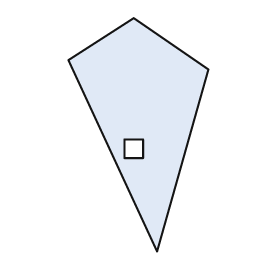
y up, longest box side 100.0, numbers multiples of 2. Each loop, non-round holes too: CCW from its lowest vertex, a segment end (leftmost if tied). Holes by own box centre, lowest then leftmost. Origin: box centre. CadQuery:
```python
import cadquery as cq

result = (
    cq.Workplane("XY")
    .moveTo(8.0, -50.0)
    .lineTo(30.0, 28.0)
    .lineTo(-2.0, 50.0)
    .lineTo(-30.0, 32.0)
    .close()
    .moveTo(-6.0, -10.0)
    .lineTo(2.0, -10.0)
    .lineTo(2.0, -2.0)
    .lineTo(-6.0, -2.0)
    .close()
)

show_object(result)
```